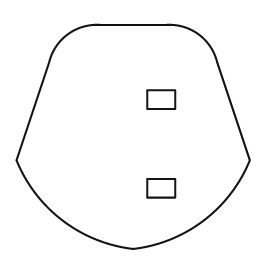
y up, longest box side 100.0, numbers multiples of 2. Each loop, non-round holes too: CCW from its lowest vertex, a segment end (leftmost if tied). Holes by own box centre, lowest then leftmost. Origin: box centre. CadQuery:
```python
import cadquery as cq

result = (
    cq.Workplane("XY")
    .moveTo(0.0, -48.0)
    .threePointArc((30.0, -36.0), (50.0, -10.0))
    .lineTo(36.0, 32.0)
    .threePointArc((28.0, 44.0), (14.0, 48.0))
    .lineTo(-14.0, 48.0)
    .threePointArc((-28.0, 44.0), (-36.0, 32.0))
    .lineTo(-50.0, -10.0)
    .threePointArc((-30.0, -36.0), (0.0, -48.0))
    .close()
    .moveTo(6.0, -26.0)
    .lineTo(18.0, -26.0)
    .lineTo(18.0, -18.0)
    .lineTo(6.0, -18.0)
    .close()
    .moveTo(6.0, 12.0)
    .lineTo(18.0, 12.0)
    .lineTo(18.0, 20.0)
    .lineTo(6.0, 20.0)
    .close()
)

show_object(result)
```